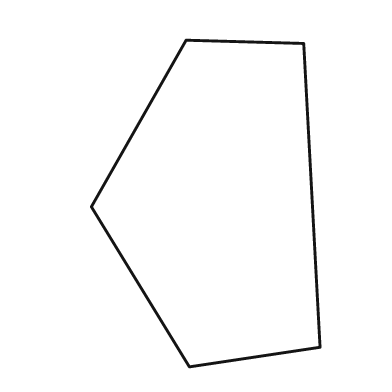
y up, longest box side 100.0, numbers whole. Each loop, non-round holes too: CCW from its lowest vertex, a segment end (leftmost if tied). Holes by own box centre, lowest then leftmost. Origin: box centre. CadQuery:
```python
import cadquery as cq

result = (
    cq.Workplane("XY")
    .moveTo(-5.0, -50.0)
    .lineTo(35.0, -44.0)
    .lineTo(30.0, 49.0)
    .lineTo(-6.0, 50.0)
    .lineTo(-35.0, -1.0)
    .close()
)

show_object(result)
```